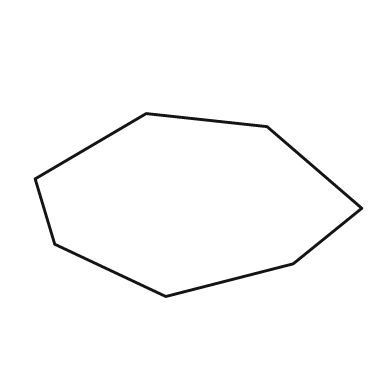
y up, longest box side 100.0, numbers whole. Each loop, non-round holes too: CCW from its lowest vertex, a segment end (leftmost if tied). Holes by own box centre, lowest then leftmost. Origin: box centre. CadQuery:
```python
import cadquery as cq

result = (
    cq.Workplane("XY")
    .moveTo(-10.0, -28.0)
    .lineTo(29.0, -18.0)
    .lineTo(50.0, -1.0)
    .lineTo(21.0, 24.0)
    .lineTo(-16.0, 28.0)
    .lineTo(-50.0, 8.0)
    .lineTo(-44.0, -12.0)
    .close()
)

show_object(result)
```